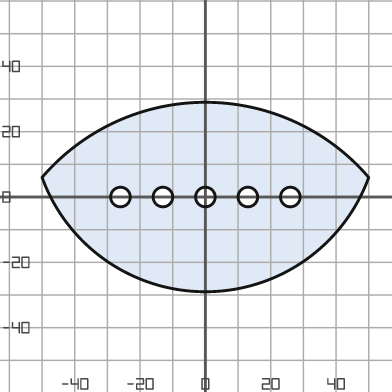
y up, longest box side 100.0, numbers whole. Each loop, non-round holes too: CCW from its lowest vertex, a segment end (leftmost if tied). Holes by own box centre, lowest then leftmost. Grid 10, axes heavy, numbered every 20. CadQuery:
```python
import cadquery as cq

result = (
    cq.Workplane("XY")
    .moveTo(-50.0, 6.0)
    .threePointArc((0.0, -29.0), (50.0, 6.0))
    .threePointArc((0.0, 29.0), (-50.0, 6.0))
    .close()
    .moveTo(-26.0, 0.0)
    .circle(3.0)
    .moveTo(-13.0, 0.0)
    .circle(3.0)
    .moveTo(0.0, 0.0)
    .circle(3.0)
    .moveTo(13.0, 0.0)
    .circle(3.0)
    .moveTo(26.0, 0.0)
    .circle(3.0)
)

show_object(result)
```